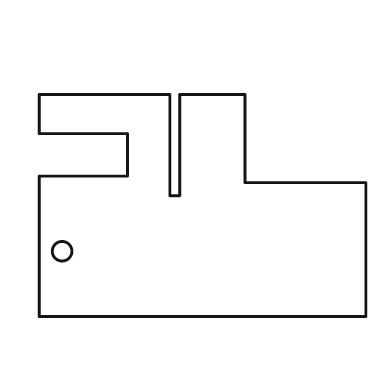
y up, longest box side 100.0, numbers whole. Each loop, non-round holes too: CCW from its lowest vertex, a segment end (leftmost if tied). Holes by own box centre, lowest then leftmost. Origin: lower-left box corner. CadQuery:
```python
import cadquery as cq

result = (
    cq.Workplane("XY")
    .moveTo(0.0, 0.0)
    .lineTo(100.0, 0.0)
    .lineTo(100.0, 41.0)
    .lineTo(63.0, 41.0)
    .lineTo(63.0, 68.0)
    .lineTo(43.0, 68.0)
    .lineTo(43.0, 37.0)
    .lineTo(40.0, 37.0)
    .lineTo(40.0, 68.0)
    .lineTo(0.0, 68.0)
    .lineTo(0.0, 56.0)
    .lineTo(27.0, 56.0)
    .lineTo(27.0, 43.0)
    .lineTo(0.0, 43.0)
    .close()
    .moveTo(7.0, 20.0)
    .circle(3.0)
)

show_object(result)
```